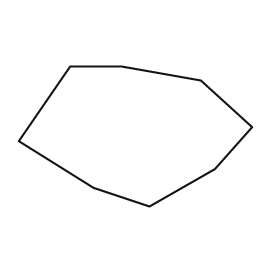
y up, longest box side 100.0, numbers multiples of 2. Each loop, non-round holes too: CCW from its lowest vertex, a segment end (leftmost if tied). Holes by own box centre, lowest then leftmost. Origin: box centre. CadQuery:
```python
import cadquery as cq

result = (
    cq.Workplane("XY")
    .moveTo(6.0, -30.0)
    .lineTo(34.0, -14.0)
    .lineTo(50.0, 4.0)
    .lineTo(28.0, 24.0)
    .lineTo(-6.0, 30.0)
    .lineTo(-28.0, 30.0)
    .lineTo(-50.0, -2.0)
    .lineTo(-18.0, -22.0)
    .close()
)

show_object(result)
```